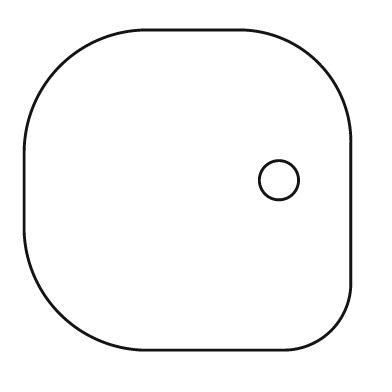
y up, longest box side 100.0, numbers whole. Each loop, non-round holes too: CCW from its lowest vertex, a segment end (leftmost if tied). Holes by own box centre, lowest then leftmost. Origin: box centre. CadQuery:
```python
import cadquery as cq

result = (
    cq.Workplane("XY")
    .moveTo(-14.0, -49.0)
    .lineTo(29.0, -49.0)
    .threePointArc((44.0, -43.0), (50.0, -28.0))
    .lineTo(50.0, 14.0)
    .threePointArc((40.0, 39.0), (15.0, 49.0))
    .lineTo(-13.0, 49.0)
    .threePointArc((-39.0, 38.0), (-50.0, 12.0))
    .lineTo(-50.0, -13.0)
    .threePointArc((-39.0, -38.0), (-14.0, -49.0))
    .close()
    .moveTo(28.0, 3.0)
    .circle(6.0)
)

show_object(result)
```